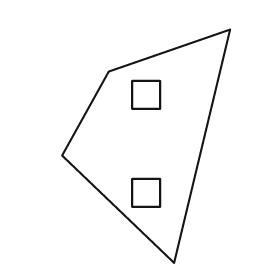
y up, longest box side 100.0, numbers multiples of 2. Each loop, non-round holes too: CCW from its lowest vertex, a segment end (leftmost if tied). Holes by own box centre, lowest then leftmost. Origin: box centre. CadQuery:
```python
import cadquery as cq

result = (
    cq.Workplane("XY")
    .moveTo(12.0, -50.0)
    .lineTo(36.0, 50.0)
    .lineTo(-16.0, 32.0)
    .lineTo(-36.0, -4.0)
    .close()
    .moveTo(-6.0, -26.0)
    .lineTo(6.0, -26.0)
    .lineTo(6.0, -14.0)
    .lineTo(-6.0, -14.0)
    .close()
    .moveTo(-6.0, 16.0)
    .lineTo(6.0, 16.0)
    .lineTo(6.0, 28.0)
    .lineTo(-6.0, 28.0)
    .close()
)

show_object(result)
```